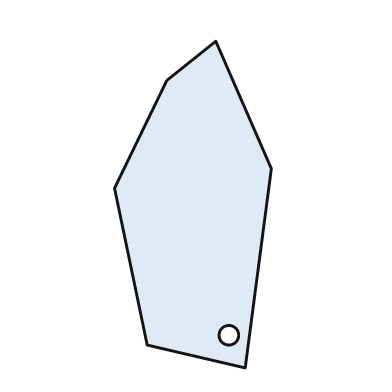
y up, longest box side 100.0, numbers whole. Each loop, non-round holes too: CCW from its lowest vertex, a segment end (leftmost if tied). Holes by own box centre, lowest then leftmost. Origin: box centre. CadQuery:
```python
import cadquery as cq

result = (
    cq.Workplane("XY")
    .moveTo(16.0, -50.0)
    .lineTo(24.0, 11.0)
    .lineTo(7.0, 50.0)
    .lineTo(-8.0, 38.0)
    .lineTo(-24.0, 5.0)
    .lineTo(-14.0, -43.0)
    .close()
    .moveTo(11.0, -40.0)
    .circle(3.0)
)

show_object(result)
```